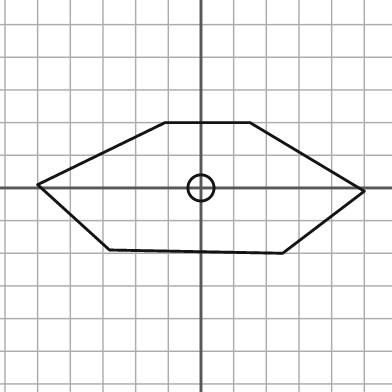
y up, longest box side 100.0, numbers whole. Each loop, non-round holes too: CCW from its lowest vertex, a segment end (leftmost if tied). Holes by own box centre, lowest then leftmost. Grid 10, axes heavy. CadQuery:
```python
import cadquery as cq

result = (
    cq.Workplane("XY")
    .moveTo(25.0, -20.0)
    .lineTo(50.0, -1.0)
    .lineTo(15.0, 20.0)
    .lineTo(-11.0, 20.0)
    .lineTo(-50.0, 1.0)
    .lineTo(-28.0, -19.0)
    .close()
    .moveTo(0.0, 0.0)
    .circle(4.0)
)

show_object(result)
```